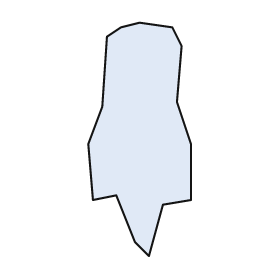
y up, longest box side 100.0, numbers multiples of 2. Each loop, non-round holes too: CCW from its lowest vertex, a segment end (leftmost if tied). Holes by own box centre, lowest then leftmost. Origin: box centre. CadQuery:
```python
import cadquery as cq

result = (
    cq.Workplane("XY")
    .moveTo(4.0, -50.0)
    .lineTo(10.0, -28.0)
    .lineTo(22.0, -26.0)
    .lineTo(22.0, -2.0)
    .lineTo(16.0, 16.0)
    .lineTo(18.0, 40.0)
    .lineTo(14.0, 48.0)
    .lineTo(0.0, 50.0)
    .lineTo(-8.0, 48.0)
    .lineTo(-14.0, 44.0)
    .lineTo(-16.0, 14.0)
    .lineTo(-22.0, -2.0)
    .lineTo(-20.0, -26.0)
    .lineTo(-10.0, -24.0)
    .lineTo(-2.0, -44.0)
    .close()
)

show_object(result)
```